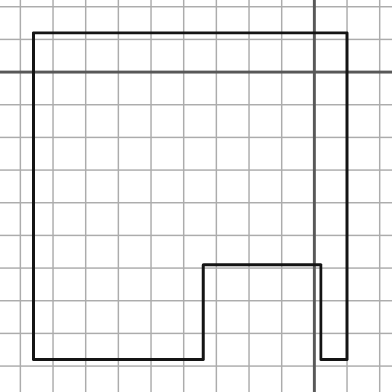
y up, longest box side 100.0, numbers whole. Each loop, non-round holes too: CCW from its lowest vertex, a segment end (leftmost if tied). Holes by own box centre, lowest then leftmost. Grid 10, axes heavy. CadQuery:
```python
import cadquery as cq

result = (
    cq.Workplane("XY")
    .moveTo(-86.0, -88.0)
    .lineTo(-34.0, -88.0)
    .lineTo(-34.0, -59.0)
    .lineTo(2.0, -59.0)
    .lineTo(2.0, -88.0)
    .lineTo(10.0, -88.0)
    .lineTo(10.0, 12.0)
    .lineTo(-86.0, 12.0)
    .close()
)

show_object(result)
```